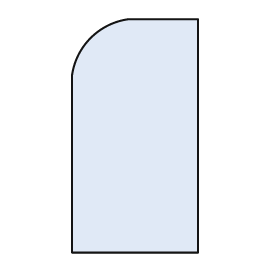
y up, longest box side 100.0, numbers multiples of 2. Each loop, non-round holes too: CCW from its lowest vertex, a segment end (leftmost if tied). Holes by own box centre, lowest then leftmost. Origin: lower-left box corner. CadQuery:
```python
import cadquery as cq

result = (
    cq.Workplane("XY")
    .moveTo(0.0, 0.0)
    .lineTo(54.0, 0.0)
    .lineTo(54.0, 100.0)
    .lineTo(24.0, 100.0)
    .threePointArc((8.0, 92.0), (0.0, 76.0))
    .close()
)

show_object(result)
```